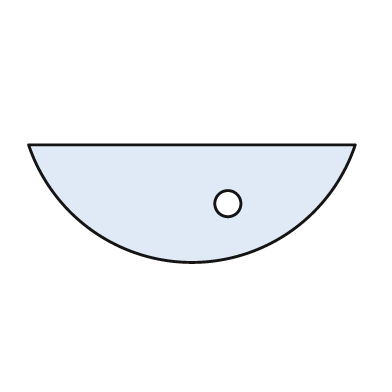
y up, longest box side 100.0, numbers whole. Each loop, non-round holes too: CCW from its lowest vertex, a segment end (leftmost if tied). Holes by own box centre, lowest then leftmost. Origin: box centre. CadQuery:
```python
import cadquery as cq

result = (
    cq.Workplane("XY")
    .moveTo(-50.0, 18.0)
    .threePointArc((0.0, -18.0), (50.0, 18.0))
    .close()
    .moveTo(11.0, 0.0)
    .circle(4.0)
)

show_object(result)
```